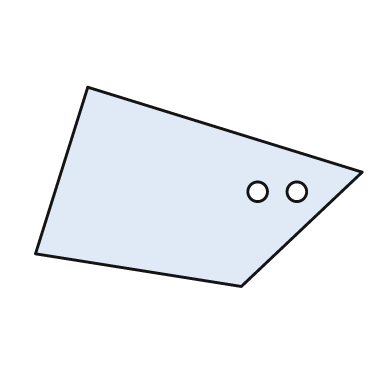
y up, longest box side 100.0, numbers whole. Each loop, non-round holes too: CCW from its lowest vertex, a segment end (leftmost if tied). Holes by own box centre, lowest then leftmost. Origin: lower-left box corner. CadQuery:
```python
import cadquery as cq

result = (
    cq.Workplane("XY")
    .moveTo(63.0, 0.0)
    .lineTo(100.0, 35.0)
    .lineTo(16.0, 61.0)
    .lineTo(0.0, 10.0)
    .close()
    .moveTo(68.0, 29.0)
    .circle(3.0)
    .moveTo(80.0, 29.0)
    .circle(3.0)
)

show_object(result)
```